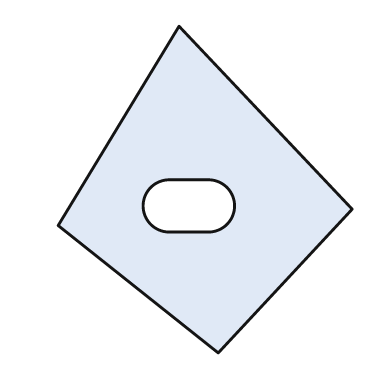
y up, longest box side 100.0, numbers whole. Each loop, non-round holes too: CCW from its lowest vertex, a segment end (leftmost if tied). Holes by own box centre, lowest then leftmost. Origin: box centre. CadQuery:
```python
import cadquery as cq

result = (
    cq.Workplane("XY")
    .moveTo(4.0, -50.0)
    .lineTo(45.0, -6.0)
    .lineTo(-8.0, 50.0)
    .lineTo(-45.0, -11.0)
    .close()
    .moveTo(-11.0, -13.0)
    .lineTo(1.0, -13.0)
    .threePointArc((9.0, -5.0), (1.0, 3.0))
    .lineTo(-11.0, 3.0)
    .threePointArc((-19.0, -5.0), (-11.0, -13.0))
    .close()
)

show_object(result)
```